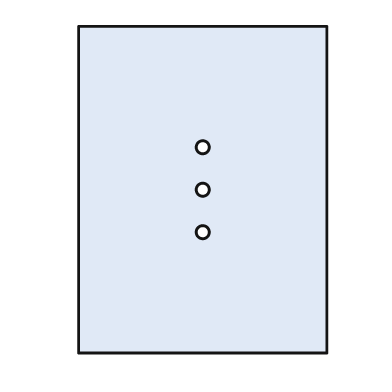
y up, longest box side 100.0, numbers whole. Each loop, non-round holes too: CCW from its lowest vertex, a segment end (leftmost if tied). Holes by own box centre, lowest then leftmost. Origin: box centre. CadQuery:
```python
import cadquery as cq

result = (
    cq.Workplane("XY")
    .moveTo(-38.0, -50.0)
    .lineTo(38.0, -50.0)
    .lineTo(38.0, 50.0)
    .lineTo(-38.0, 50.0)
    .close()
    .moveTo(0.0, -13.0)
    .circle(2.0)
    .moveTo(0.0, 0.0)
    .circle(2.0)
    .moveTo(0.0, 13.0)
    .circle(2.0)
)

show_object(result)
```